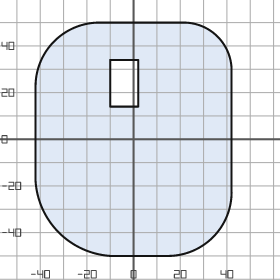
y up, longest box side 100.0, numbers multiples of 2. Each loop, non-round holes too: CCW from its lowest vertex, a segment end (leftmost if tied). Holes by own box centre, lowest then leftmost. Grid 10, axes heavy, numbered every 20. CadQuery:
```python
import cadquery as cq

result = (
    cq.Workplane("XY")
    .moveTo(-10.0, -50.0)
    .lineTo(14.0, -50.0)
    .threePointArc((34.0, -42.0), (42.0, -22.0))
    .lineTo(42.0, 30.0)
    .threePointArc((36.0, 44.0), (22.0, 50.0))
    .lineTo(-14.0, 50.0)
    .threePointArc((-34.0, 42.0), (-42.0, 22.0))
    .lineTo(-42.0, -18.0)
    .threePointArc((-32.0, -40.0), (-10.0, -50.0))
    .close()
    .moveTo(-10.0, 14.0)
    .lineTo(2.0, 14.0)
    .lineTo(2.0, 34.0)
    .lineTo(-10.0, 34.0)
    .close()
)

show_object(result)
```